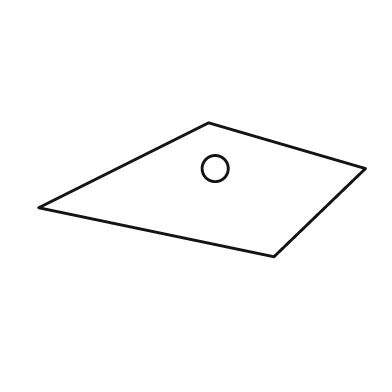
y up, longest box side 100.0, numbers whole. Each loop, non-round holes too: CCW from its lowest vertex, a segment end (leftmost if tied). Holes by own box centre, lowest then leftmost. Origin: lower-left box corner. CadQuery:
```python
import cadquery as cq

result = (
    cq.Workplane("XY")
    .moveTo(72.0, 0.0)
    .lineTo(100.0, 27.0)
    .lineTo(52.0, 41.0)
    .lineTo(0.0, 15.0)
    .close()
    .moveTo(54.0, 27.0)
    .circle(4.0)
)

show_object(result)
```